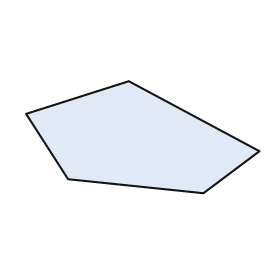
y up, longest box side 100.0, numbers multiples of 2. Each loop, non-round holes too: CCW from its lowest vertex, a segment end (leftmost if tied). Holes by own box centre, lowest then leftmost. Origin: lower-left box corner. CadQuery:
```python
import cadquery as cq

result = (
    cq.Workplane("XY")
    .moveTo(76.0, 0.0)
    .lineTo(100.0, 18.0)
    .lineTo(44.0, 48.0)
    .lineTo(0.0, 34.0)
    .lineTo(18.0, 6.0)
    .close()
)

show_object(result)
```